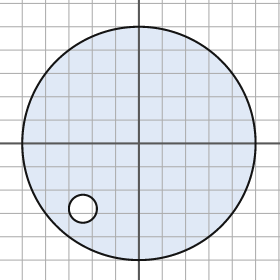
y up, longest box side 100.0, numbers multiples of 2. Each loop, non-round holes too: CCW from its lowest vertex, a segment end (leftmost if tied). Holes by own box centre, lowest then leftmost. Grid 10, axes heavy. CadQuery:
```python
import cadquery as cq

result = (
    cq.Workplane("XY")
    .moveTo(0.0, 0.0)
    .circle(50.0)
    .moveTo(-24.0, -28.0)
    .circle(6.0)
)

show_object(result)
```